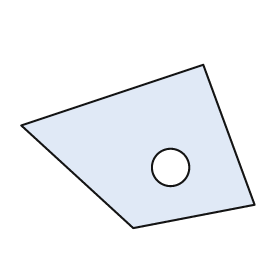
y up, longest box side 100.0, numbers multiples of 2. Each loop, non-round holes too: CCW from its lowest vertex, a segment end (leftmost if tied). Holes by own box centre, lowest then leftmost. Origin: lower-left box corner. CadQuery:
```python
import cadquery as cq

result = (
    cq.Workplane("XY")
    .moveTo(48.0, 0.0)
    .lineTo(100.0, 10.0)
    .lineTo(78.0, 70.0)
    .lineTo(0.0, 44.0)
    .close()
    .moveTo(64.0, 26.0)
    .circle(8.0)
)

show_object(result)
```